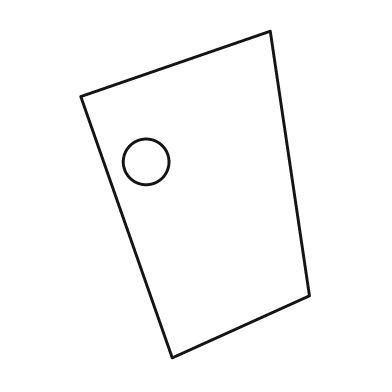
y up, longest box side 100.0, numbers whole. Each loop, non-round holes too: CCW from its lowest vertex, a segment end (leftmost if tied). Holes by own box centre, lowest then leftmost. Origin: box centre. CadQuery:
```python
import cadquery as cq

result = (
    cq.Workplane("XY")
    .moveTo(-7.0, -50.0)
    .lineTo(35.0, -31.0)
    .lineTo(23.0, 50.0)
    .lineTo(-35.0, 30.0)
    .close()
    .moveTo(-15.0, 10.0)
    .circle(7.0)
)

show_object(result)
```